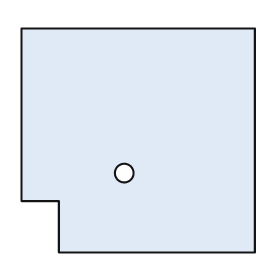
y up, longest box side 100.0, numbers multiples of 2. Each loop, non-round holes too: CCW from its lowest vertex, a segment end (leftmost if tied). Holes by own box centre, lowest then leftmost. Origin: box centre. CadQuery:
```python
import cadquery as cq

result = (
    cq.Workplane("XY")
    .moveTo(-34.0, -48.0)
    .lineTo(50.0, -48.0)
    .lineTo(50.0, 48.0)
    .lineTo(-50.0, 48.0)
    .lineTo(-50.0, -26.0)
    .lineTo(-34.0, -26.0)
    .close()
    .moveTo(-6.0, -14.0)
    .circle(4.0)
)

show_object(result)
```